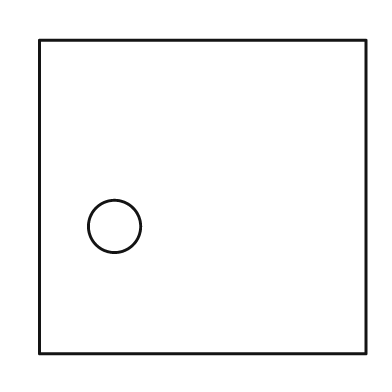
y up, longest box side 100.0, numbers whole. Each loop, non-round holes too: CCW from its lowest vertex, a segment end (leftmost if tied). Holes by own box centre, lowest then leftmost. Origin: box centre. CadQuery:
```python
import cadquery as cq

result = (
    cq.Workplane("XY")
    .moveTo(-50.0, -48.0)
    .lineTo(50.0, -48.0)
    .lineTo(50.0, 48.0)
    .lineTo(-50.0, 48.0)
    .close()
    .moveTo(-27.0, -9.0)
    .circle(8.0)
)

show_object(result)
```